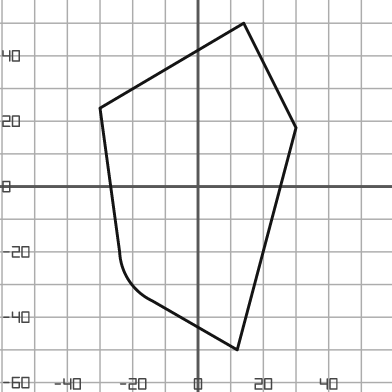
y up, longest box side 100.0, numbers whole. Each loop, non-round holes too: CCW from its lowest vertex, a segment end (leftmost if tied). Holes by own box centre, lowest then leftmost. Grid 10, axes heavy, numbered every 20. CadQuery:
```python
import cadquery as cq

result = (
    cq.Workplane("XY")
    .moveTo(12.0, -50.0)
    .lineTo(30.0, 18.0)
    .lineTo(14.0, 50.0)
    .lineTo(-30.0, 24.0)
    .lineTo(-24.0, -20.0)
    .threePointArc((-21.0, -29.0), (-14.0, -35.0))
    .close()
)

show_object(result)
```